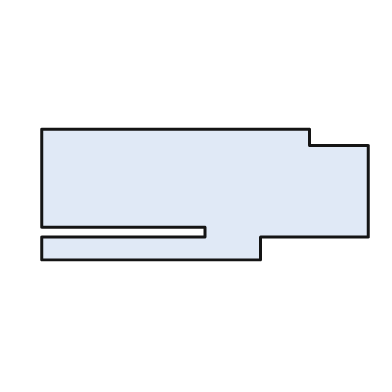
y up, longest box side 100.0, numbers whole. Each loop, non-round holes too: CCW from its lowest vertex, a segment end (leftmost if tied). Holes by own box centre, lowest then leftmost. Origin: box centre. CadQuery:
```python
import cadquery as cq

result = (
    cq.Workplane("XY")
    .moveTo(-50.0, -20.0)
    .lineTo(17.0, -20.0)
    .lineTo(17.0, -13.0)
    .lineTo(50.0, -13.0)
    .lineTo(50.0, 15.0)
    .lineTo(32.0, 15.0)
    .lineTo(32.0, 20.0)
    .lineTo(-50.0, 20.0)
    .lineTo(-50.0, -10.0)
    .lineTo(0.0, -10.0)
    .lineTo(0.0, -13.0)
    .lineTo(-50.0, -13.0)
    .close()
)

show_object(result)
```